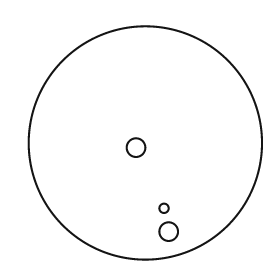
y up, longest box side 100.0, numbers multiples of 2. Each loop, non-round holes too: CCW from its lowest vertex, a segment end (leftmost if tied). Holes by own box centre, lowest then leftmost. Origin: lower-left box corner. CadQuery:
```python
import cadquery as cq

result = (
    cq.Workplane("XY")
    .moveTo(50.0, 50.0)
    .circle(50.0)
    .moveTo(60.0, 12.0)
    .circle(4.0)
    .moveTo(58.0, 22.0)
    .circle(2.0)
    .moveTo(46.0, 48.0)
    .circle(4.0)
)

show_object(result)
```